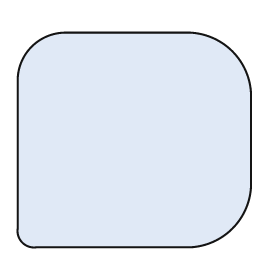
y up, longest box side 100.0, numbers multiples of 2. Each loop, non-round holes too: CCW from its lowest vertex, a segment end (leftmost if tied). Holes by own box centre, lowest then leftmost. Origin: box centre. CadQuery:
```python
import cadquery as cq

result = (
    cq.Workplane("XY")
    .moveTo(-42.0, -46.0)
    .lineTo(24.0, -46.0)
    .threePointArc((42.0, -38.0), (50.0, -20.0))
    .lineTo(50.0, 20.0)
    .threePointArc((42.0, 38.0), (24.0, 46.0))
    .lineTo(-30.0, 46.0)
    .threePointArc((-44.0, 40.0), (-50.0, 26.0))
    .lineTo(-50.0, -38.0)
    .threePointArc((-48.0, -44.0), (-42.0, -46.0))
    .close()
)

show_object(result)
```